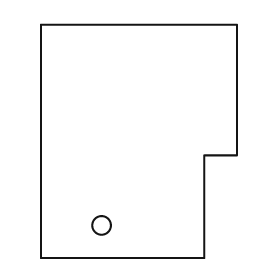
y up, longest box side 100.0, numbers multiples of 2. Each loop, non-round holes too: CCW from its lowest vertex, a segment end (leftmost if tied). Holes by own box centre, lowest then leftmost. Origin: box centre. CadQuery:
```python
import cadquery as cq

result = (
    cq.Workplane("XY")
    .moveTo(-42.0, -50.0)
    .lineTo(28.0, -50.0)
    .lineTo(28.0, -6.0)
    .lineTo(42.0, -6.0)
    .lineTo(42.0, 50.0)
    .lineTo(-42.0, 50.0)
    .close()
    .moveTo(-16.0, -36.0)
    .circle(4.0)
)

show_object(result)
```